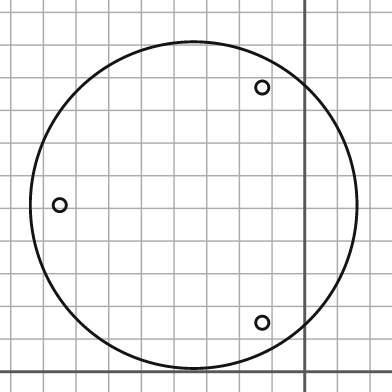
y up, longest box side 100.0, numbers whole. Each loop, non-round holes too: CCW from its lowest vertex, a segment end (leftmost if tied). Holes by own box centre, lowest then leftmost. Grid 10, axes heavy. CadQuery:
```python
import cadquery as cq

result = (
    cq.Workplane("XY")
    .moveTo(-34.0, 51.0)
    .circle(50.0)
    .moveTo(-13.0, 15.0)
    .circle(2.0)
    .moveTo(-75.0, 51.0)
    .circle(2.0)
    .moveTo(-13.0, 87.0)
    .circle(2.0)
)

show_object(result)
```